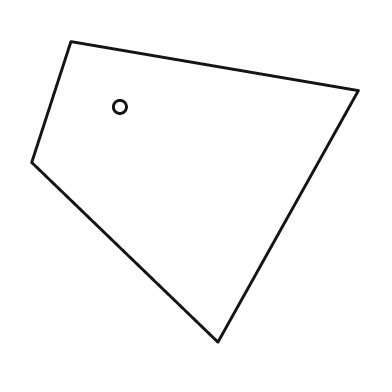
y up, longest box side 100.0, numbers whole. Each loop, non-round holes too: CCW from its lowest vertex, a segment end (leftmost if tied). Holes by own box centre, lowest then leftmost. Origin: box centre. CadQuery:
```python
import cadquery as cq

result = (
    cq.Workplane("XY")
    .moveTo(7.0, -46.0)
    .lineTo(50.0, 31.0)
    .lineTo(-38.0, 46.0)
    .lineTo(-50.0, 9.0)
    .close()
    .moveTo(-23.0, 26.0)
    .circle(2.0)
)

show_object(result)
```